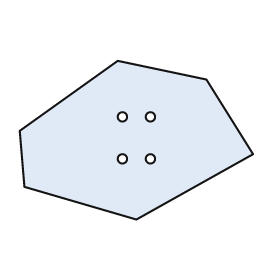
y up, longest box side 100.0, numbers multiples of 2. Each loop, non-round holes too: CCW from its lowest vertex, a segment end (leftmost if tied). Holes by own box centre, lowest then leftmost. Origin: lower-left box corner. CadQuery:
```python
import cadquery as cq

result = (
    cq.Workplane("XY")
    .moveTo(50.0, 0.0)
    .lineTo(100.0, 28.0)
    .lineTo(80.0, 60.0)
    .lineTo(42.0, 68.0)
    .lineTo(0.0, 38.0)
    .lineTo(2.0, 14.0)
    .close()
    .moveTo(44.0, 26.0)
    .circle(2.0)
    .moveTo(56.0, 26.0)
    .circle(2.0)
    .moveTo(44.0, 44.0)
    .circle(2.0)
    .moveTo(56.0, 44.0)
    .circle(2.0)
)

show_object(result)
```